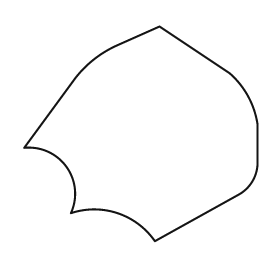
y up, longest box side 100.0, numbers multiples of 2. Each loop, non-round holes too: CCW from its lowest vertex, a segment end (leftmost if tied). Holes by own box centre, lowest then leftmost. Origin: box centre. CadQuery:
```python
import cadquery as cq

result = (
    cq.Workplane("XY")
    .moveTo(6.0, -46.0)
    .lineTo(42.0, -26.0)
    .threePointArc((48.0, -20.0), (50.0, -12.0))
    .lineTo(50.0, 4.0)
    .threePointArc((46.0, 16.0), (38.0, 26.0))
    .lineTo(8.0, 46.0)
    .lineTo(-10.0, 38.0)
    .threePointArc((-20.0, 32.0), (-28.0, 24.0))
    .lineTo(-50.0, -6.0)
    .threePointArc((-32.0, -14.0), (-30.0, -34.0))
    .threePointArc((-10.0, -34.0), (6.0, -46.0))
    .close()
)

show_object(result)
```